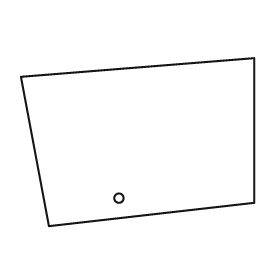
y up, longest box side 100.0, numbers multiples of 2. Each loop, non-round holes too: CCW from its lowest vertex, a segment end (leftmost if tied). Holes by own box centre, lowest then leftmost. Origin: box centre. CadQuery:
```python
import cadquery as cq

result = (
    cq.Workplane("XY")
    .moveTo(-38.0, -36.0)
    .lineTo(50.0, -26.0)
    .lineTo(50.0, 36.0)
    .lineTo(-50.0, 28.0)
    .close()
    .moveTo(-8.0, -24.0)
    .circle(2.0)
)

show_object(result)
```